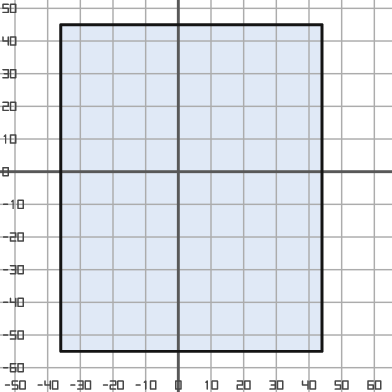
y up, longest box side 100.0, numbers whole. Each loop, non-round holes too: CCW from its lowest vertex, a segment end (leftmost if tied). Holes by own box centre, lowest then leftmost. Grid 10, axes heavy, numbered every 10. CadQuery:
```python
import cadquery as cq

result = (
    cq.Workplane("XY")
    .moveTo(-36.0, -55.0)
    .lineTo(44.0, -55.0)
    .lineTo(44.0, 45.0)
    .lineTo(-36.0, 45.0)
    .close()
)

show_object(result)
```